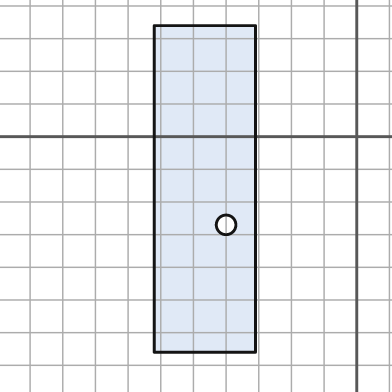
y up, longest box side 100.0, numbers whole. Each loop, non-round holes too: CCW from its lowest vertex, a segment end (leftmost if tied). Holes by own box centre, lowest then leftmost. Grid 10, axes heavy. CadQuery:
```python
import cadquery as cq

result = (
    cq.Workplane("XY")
    .moveTo(-62.0, -66.0)
    .lineTo(-31.0, -66.0)
    .lineTo(-31.0, 34.0)
    .lineTo(-62.0, 34.0)
    .close()
    .moveTo(-40.0, -27.0)
    .circle(3.0)
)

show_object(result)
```